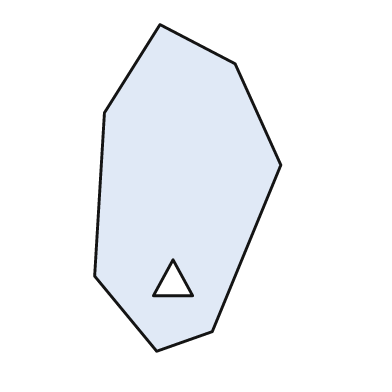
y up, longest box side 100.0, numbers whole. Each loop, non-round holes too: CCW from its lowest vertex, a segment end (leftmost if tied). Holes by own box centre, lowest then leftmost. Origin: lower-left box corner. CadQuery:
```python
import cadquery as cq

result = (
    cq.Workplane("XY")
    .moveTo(19.0, 0.0)
    .lineTo(36.0, 6.0)
    .lineTo(57.0, 57.0)
    .lineTo(43.0, 88.0)
    .lineTo(20.0, 100.0)
    .lineTo(3.0, 73.0)
    .lineTo(0.0, 23.0)
    .close()
    .moveTo(18.0, 17.0)
    .lineTo(30.0, 17.0)
    .lineTo(24.0, 28.0)
    .close()
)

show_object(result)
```